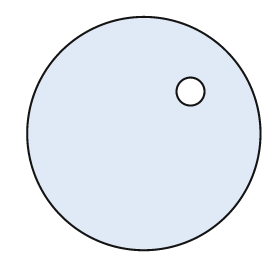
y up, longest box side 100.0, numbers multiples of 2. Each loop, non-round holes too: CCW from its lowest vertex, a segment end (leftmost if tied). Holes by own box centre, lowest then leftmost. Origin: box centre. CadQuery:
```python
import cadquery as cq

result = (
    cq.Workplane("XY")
    .moveTo(0.0, 0.0)
    .circle(50.0)
    .moveTo(20.0, 18.0)
    .circle(6.0)
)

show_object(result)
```